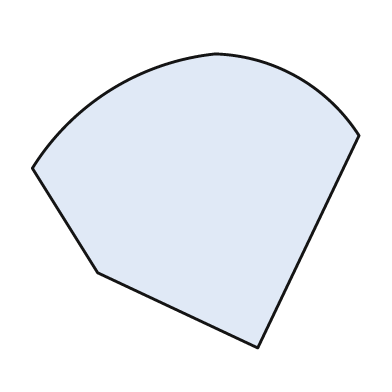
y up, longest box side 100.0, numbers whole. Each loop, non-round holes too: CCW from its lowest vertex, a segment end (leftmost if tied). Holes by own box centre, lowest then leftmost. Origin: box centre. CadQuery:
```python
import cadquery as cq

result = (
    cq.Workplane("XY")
    .moveTo(19.0, -45.0)
    .lineTo(50.0, 20.0)
    .threePointArc((31.0, 38.0), (6.0, 45.0))
    .threePointArc((-26.0, 34.0), (-50.0, 10.0))
    .lineTo(-30.0, -22.0)
    .close()
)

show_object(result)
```